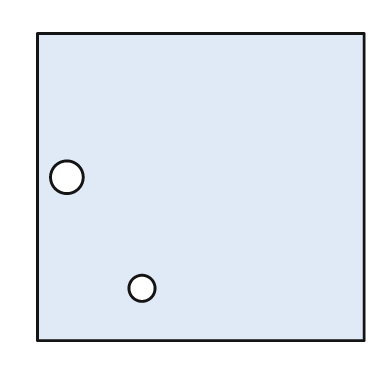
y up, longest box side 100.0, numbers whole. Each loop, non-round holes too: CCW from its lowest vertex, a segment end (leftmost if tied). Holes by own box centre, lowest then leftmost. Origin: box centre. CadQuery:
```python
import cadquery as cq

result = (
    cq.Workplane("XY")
    .moveTo(-50.0, -47.0)
    .lineTo(50.0, -47.0)
    .lineTo(50.0, 47.0)
    .lineTo(-50.0, 47.0)
    .close()
    .moveTo(-18.0, -31.0)
    .circle(4.0)
    .moveTo(-41.0, 3.0)
    .circle(5.0)
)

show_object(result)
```